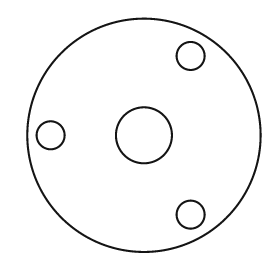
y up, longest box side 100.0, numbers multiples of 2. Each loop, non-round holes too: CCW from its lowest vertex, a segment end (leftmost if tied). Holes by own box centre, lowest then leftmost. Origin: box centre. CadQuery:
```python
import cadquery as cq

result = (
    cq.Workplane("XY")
    .moveTo(0.0, 0.0)
    .circle(50.0)
    .moveTo(20.0, -34.0)
    .circle(6.0)
    .moveTo(-40.0, 0.0)
    .circle(6.0)
    .moveTo(0.0, 0.0)
    .circle(12.0)
    .moveTo(20.0, 34.0)
    .circle(6.0)
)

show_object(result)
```